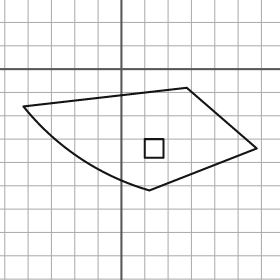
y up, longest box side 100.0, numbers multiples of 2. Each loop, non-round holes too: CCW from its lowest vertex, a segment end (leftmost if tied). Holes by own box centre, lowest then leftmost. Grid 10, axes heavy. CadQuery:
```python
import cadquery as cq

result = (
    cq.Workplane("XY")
    .moveTo(12.0, -52.0)
    .lineTo(58.0, -34.0)
    .lineTo(28.0, -8.0)
    .lineTo(-42.0, -16.0)
    .threePointArc((-18.0, -38.0), (12.0, -52.0))
    .close()
    .moveTo(10.0, -38.0)
    .lineTo(18.0, -38.0)
    .lineTo(18.0, -30.0)
    .lineTo(10.0, -30.0)
    .close()
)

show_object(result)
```